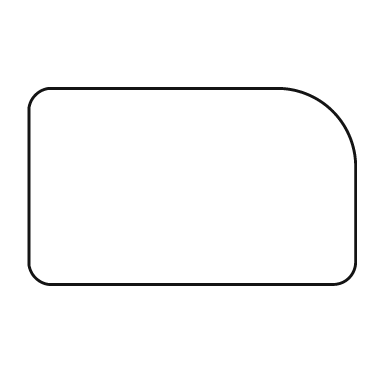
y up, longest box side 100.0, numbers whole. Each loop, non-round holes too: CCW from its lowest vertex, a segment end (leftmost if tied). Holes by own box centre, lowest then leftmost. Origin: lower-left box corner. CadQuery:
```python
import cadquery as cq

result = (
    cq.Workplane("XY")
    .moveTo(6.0, 0.0)
    .lineTo(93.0, 0.0)
    .threePointArc((98.0, 2.0), (100.0, 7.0))
    .lineTo(100.0, 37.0)
    .threePointArc((93.0, 53.0), (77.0, 60.0))
    .lineTo(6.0, 60.0)
    .threePointArc((2.0, 58.0), (0.0, 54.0))
    .lineTo(0.0, 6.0)
    .threePointArc((2.0, 2.0), (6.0, 0.0))
    .close()
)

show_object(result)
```